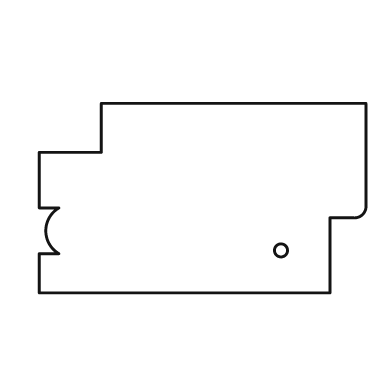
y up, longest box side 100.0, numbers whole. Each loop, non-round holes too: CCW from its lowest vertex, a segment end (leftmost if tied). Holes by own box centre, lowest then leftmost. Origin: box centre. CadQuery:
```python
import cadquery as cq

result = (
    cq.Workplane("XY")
    .moveTo(-50.0, -29.0)
    .lineTo(39.0, -29.0)
    .lineTo(39.0, -6.0)
    .lineTo(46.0, -6.0)
    .threePointArc((49.0, -5.0), (50.0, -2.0))
    .lineTo(50.0, 29.0)
    .lineTo(-31.0, 29.0)
    .lineTo(-31.0, 14.0)
    .lineTo(-50.0, 14.0)
    .lineTo(-50.0, -3.0)
    .lineTo(-44.0, -3.0)
    .threePointArc((-48.0, -10.0), (-44.0, -17.0))
    .lineTo(-50.0, -17.0)
    .close()
    .moveTo(24.0, -16.0)
    .circle(2.0)
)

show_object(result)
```